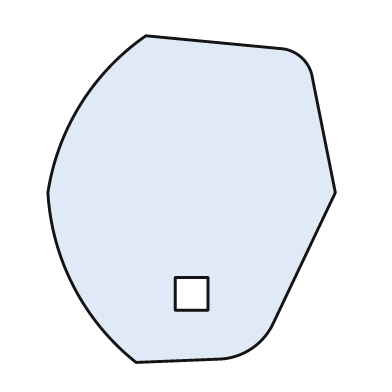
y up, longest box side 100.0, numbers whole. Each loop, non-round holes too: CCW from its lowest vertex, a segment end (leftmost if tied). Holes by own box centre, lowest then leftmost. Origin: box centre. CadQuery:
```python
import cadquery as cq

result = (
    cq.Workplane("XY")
    .moveTo(-17.0, -50.0)
    .lineTo(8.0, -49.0)
    .threePointArc((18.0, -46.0), (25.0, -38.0))
    .lineTo(44.0, 2.0)
    .lineTo(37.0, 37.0)
    .threePointArc((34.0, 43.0), (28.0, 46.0))
    .lineTo(-14.0, 50.0)
    .threePointArc((-34.0, 29.0), (-44.0, 2.0))
    .threePointArc((-36.0, -27.0), (-17.0, -50.0))
    .close()
    .moveTo(-5.0, -34.0)
    .lineTo(5.0, -34.0)
    .lineTo(5.0, -24.0)
    .lineTo(-5.0, -24.0)
    .close()
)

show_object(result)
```